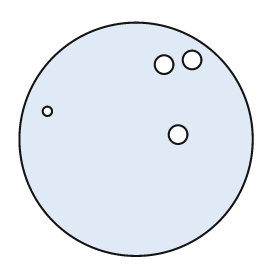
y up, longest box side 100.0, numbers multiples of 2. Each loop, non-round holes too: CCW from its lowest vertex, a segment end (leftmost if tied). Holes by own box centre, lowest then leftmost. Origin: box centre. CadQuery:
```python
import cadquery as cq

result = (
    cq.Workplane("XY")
    .moveTo(0.0, 0.0)
    .circle(50.0)
    .moveTo(18.0, 2.0)
    .circle(4.0)
    .moveTo(-38.0, 12.0)
    .circle(2.0)
    .moveTo(12.0, 32.0)
    .circle(4.0)
    .moveTo(24.0, 34.0)
    .circle(4.0)
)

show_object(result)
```